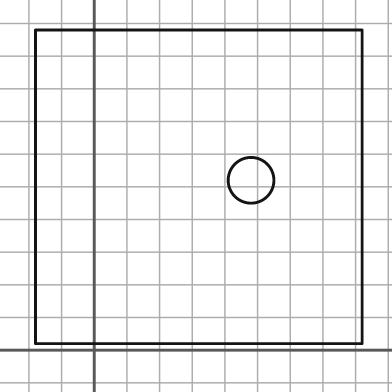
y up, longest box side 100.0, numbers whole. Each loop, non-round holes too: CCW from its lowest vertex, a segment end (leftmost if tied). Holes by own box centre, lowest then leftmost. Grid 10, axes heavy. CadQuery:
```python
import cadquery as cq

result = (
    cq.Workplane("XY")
    .moveTo(-18.0, 2.0)
    .lineTo(82.0, 2.0)
    .lineTo(82.0, 98.0)
    .lineTo(-18.0, 98.0)
    .close()
    .moveTo(48.0, 52.0)
    .circle(7.0)
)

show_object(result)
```